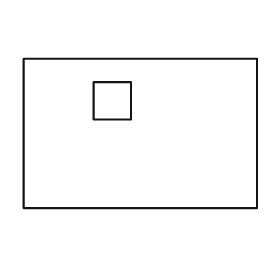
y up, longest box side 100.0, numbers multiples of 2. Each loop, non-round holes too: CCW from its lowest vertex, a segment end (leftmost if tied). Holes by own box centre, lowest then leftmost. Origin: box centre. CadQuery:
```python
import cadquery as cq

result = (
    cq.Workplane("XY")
    .moveTo(-50.0, -32.0)
    .lineTo(50.0, -32.0)
    .lineTo(50.0, 32.0)
    .lineTo(-50.0, 32.0)
    .close()
    .moveTo(-20.0, 6.0)
    .lineTo(-4.0, 6.0)
    .lineTo(-4.0, 22.0)
    .lineTo(-20.0, 22.0)
    .close()
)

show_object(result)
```